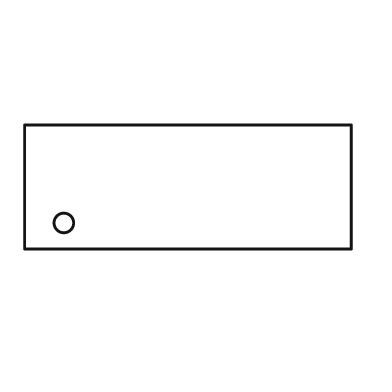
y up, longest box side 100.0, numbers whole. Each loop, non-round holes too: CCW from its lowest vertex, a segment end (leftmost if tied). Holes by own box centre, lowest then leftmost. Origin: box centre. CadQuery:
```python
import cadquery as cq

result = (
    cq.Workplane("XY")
    .moveTo(-50.0, -19.0)
    .lineTo(50.0, -19.0)
    .lineTo(50.0, 19.0)
    .lineTo(-50.0, 19.0)
    .close()
    .moveTo(-38.0, -11.0)
    .circle(3.0)
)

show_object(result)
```